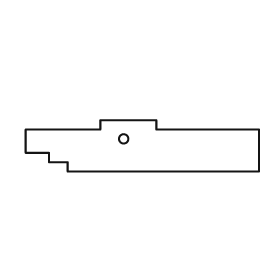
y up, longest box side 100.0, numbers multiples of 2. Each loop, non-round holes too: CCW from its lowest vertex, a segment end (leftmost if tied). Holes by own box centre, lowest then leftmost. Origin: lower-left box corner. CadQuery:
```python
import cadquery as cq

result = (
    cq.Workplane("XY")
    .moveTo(18.0, 0.0)
    .lineTo(100.0, 0.0)
    .lineTo(100.0, 18.0)
    .lineTo(56.0, 18.0)
    .lineTo(56.0, 22.0)
    .lineTo(32.0, 22.0)
    .lineTo(32.0, 18.0)
    .lineTo(0.0, 18.0)
    .lineTo(0.0, 8.0)
    .lineTo(10.0, 8.0)
    .lineTo(10.0, 4.0)
    .lineTo(18.0, 4.0)
    .close()
    .moveTo(42.0, 14.0)
    .circle(2.0)
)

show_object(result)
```